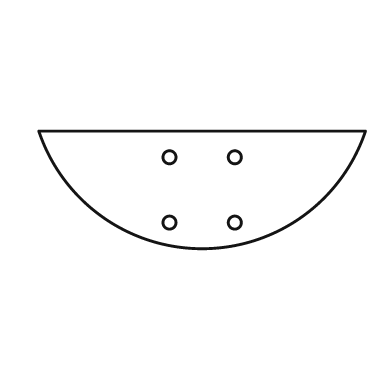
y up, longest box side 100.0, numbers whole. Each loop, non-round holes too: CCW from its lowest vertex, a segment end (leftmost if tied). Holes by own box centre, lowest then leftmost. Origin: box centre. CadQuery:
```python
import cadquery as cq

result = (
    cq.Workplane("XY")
    .moveTo(-50.0, 18.0)
    .threePointArc((0.0, -18.0), (50.0, 18.0))
    .close()
    .moveTo(-10.0, -10.0)
    .circle(2.0)
    .moveTo(10.0, -10.0)
    .circle(2.0)
    .moveTo(-10.0, 10.0)
    .circle(2.0)
    .moveTo(10.0, 10.0)
    .circle(2.0)
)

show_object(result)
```